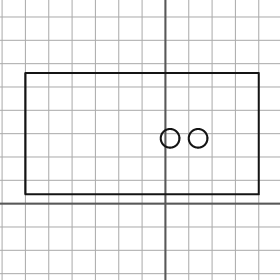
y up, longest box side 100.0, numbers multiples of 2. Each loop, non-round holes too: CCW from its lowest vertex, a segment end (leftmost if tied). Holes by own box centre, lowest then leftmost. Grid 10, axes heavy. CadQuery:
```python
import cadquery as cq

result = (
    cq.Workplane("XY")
    .moveTo(-60.0, 4.0)
    .lineTo(40.0, 4.0)
    .lineTo(40.0, 56.0)
    .lineTo(-60.0, 56.0)
    .close()
    .moveTo(2.0, 28.0)
    .circle(4.0)
    .moveTo(14.0, 28.0)
    .circle(4.0)
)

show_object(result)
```